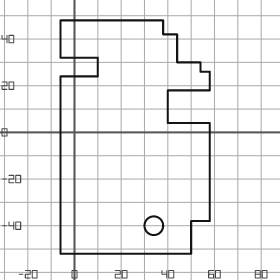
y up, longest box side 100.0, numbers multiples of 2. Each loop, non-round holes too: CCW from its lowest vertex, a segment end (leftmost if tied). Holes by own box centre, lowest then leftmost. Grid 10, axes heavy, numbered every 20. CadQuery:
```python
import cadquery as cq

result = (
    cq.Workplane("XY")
    .moveTo(-6.0, -52.0)
    .lineTo(50.0, -52.0)
    .lineTo(50.0, -38.0)
    .lineTo(58.0, -38.0)
    .lineTo(58.0, 4.0)
    .lineTo(40.0, 4.0)
    .lineTo(40.0, 18.0)
    .lineTo(58.0, 18.0)
    .lineTo(58.0, 26.0)
    .lineTo(54.0, 26.0)
    .lineTo(54.0, 30.0)
    .lineTo(44.0, 30.0)
    .lineTo(44.0, 42.0)
    .lineTo(38.0, 42.0)
    .lineTo(38.0, 48.0)
    .lineTo(-6.0, 48.0)
    .lineTo(-6.0, 32.0)
    .lineTo(10.0, 32.0)
    .lineTo(10.0, 24.0)
    .lineTo(-6.0, 24.0)
    .close()
    .moveTo(34.0, -40.0)
    .circle(4.0)
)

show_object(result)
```